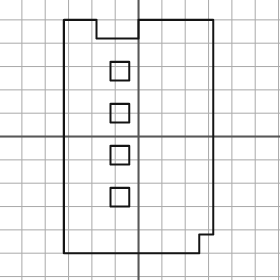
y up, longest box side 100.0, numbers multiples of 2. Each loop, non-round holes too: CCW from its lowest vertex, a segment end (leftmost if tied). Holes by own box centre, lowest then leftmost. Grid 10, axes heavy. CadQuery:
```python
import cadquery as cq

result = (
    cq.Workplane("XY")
    .moveTo(-32.0, -50.0)
    .lineTo(26.0, -50.0)
    .lineTo(26.0, -42.0)
    .lineTo(32.0, -42.0)
    .lineTo(32.0, 50.0)
    .lineTo(0.0, 50.0)
    .lineTo(0.0, 42.0)
    .lineTo(-18.0, 42.0)
    .lineTo(-18.0, 50.0)
    .lineTo(-32.0, 50.0)
    .close()
    .moveTo(-12.0, -30.0)
    .lineTo(-4.0, -30.0)
    .lineTo(-4.0, -22.0)
    .lineTo(-12.0, -22.0)
    .close()
    .moveTo(-12.0, -12.0)
    .lineTo(-4.0, -12.0)
    .lineTo(-4.0, -4.0)
    .lineTo(-12.0, -4.0)
    .close()
    .moveTo(-12.0, 6.0)
    .lineTo(-4.0, 6.0)
    .lineTo(-4.0, 14.0)
    .lineTo(-12.0, 14.0)
    .close()
    .moveTo(-12.0, 24.0)
    .lineTo(-4.0, 24.0)
    .lineTo(-4.0, 32.0)
    .lineTo(-12.0, 32.0)
    .close()
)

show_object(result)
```